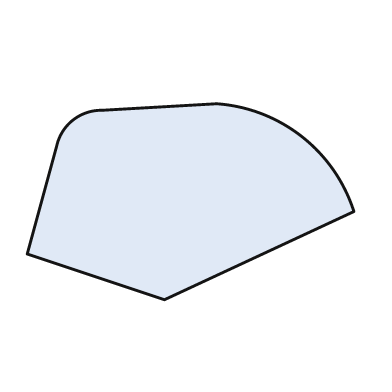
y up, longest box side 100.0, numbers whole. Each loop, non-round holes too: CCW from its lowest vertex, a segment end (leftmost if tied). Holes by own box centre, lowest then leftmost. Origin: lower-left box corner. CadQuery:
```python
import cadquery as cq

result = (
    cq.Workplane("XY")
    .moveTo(42.0, 0.0)
    .lineTo(100.0, 27.0)
    .threePointArc((84.0, 50.0), (58.0, 60.0))
    .lineTo(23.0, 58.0)
    .threePointArc((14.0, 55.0), (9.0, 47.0))
    .lineTo(0.0, 14.0)
    .close()
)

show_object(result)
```